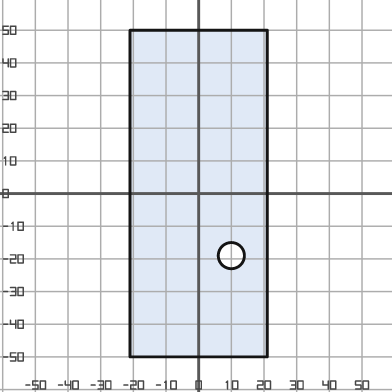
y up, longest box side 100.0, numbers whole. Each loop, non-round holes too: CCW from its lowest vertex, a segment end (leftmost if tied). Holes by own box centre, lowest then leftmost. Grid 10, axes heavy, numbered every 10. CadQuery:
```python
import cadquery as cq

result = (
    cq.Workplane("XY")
    .moveTo(-21.0, -50.0)
    .lineTo(21.0, -50.0)
    .lineTo(21.0, 50.0)
    .lineTo(-21.0, 50.0)
    .close()
    .moveTo(10.0, -19.0)
    .circle(4.0)
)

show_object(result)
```